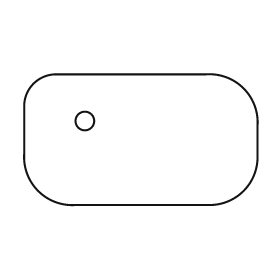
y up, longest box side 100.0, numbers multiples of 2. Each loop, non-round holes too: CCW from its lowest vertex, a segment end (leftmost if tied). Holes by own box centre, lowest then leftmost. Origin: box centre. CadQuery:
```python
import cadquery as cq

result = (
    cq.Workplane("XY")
    .moveTo(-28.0, -28.0)
    .lineTo(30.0, -28.0)
    .threePointArc((44.0, -22.0), (50.0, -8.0))
    .lineTo(50.0, 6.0)
    .threePointArc((44.0, 22.0), (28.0, 28.0))
    .lineTo(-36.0, 28.0)
    .threePointArc((-46.0, 24.0), (-50.0, 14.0))
    .lineTo(-50.0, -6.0)
    .threePointArc((-44.0, -22.0), (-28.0, -28.0))
    .close()
    .moveTo(-24.0, 8.0)
    .circle(4.0)
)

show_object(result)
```